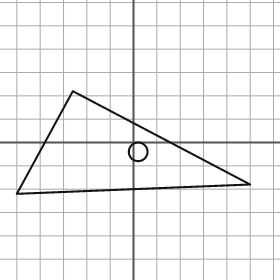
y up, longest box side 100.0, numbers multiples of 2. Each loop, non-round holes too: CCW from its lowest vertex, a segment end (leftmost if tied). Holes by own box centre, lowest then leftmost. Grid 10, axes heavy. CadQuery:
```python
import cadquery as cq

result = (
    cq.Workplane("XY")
    .moveTo(-50.0, -22.0)
    .lineTo(50.0, -18.0)
    .lineTo(-26.0, 22.0)
    .close()
    .moveTo(2.0, -4.0)
    .circle(4.0)
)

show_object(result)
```